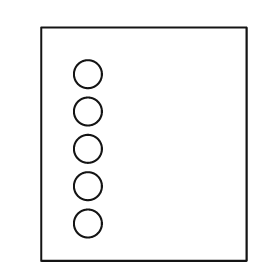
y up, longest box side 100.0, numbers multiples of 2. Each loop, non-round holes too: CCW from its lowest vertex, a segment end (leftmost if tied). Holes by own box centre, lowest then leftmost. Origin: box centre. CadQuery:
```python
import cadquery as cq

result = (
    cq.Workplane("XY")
    .moveTo(-44.0, -50.0)
    .lineTo(44.0, -50.0)
    .lineTo(44.0, 50.0)
    .lineTo(-44.0, 50.0)
    .close()
    .moveTo(-24.0, -34.0)
    .circle(6.0)
    .moveTo(-24.0, -18.0)
    .circle(6.0)
    .moveTo(-24.0, -2.0)
    .circle(6.0)
    .moveTo(-24.0, 14.0)
    .circle(6.0)
    .moveTo(-24.0, 30.0)
    .circle(6.0)
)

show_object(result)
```